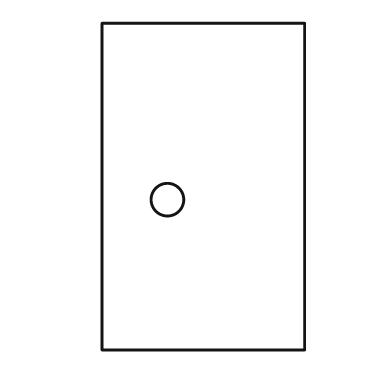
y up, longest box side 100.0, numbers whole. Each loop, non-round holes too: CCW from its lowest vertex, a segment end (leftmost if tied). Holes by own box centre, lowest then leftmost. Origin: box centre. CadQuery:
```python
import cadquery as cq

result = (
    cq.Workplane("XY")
    .moveTo(-31.0, -50.0)
    .lineTo(31.0, -50.0)
    .lineTo(31.0, 50.0)
    .lineTo(-31.0, 50.0)
    .close()
    .moveTo(-11.0, -4.0)
    .circle(5.0)
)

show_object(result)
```